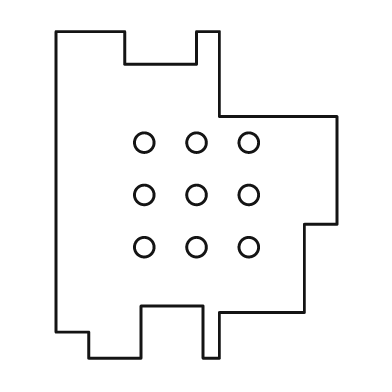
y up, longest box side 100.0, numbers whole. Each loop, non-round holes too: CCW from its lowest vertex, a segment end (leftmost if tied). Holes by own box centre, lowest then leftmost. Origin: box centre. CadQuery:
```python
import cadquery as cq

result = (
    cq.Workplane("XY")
    .moveTo(-33.0, -50.0)
    .lineTo(-17.0, -50.0)
    .lineTo(-17.0, -34.0)
    .lineTo(2.0, -34.0)
    .lineTo(2.0, -50.0)
    .lineTo(7.0, -50.0)
    .lineTo(7.0, -36.0)
    .lineTo(33.0, -36.0)
    .lineTo(33.0, -9.0)
    .lineTo(43.0, -9.0)
    .lineTo(43.0, 24.0)
    .lineTo(7.0, 24.0)
    .lineTo(7.0, 50.0)
    .lineTo(0.0, 50.0)
    .lineTo(0.0, 40.0)
    .lineTo(-22.0, 40.0)
    .lineTo(-22.0, 50.0)
    .lineTo(-43.0, 50.0)
    .lineTo(-43.0, -42.0)
    .lineTo(-33.0, -42.0)
    .close()
    .moveTo(-16.0, -16.0)
    .circle(3.0)
    .moveTo(0.0, -16.0)
    .circle(3.0)
    .moveTo(16.0, -16.0)
    .circle(3.0)
    .moveTo(-16.0, 0.0)
    .circle(3.0)
    .moveTo(0.0, 0.0)
    .circle(3.0)
    .moveTo(16.0, 0.0)
    .circle(3.0)
    .moveTo(-16.0, 16.0)
    .circle(3.0)
    .moveTo(0.0, 16.0)
    .circle(3.0)
    .moveTo(16.0, 16.0)
    .circle(3.0)
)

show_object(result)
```